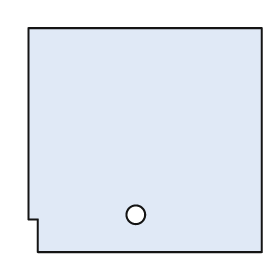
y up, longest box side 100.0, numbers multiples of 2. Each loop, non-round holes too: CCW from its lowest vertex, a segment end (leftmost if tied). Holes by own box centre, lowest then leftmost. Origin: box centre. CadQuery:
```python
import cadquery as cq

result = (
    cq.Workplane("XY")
    .moveTo(-46.0, -48.0)
    .lineTo(50.0, -48.0)
    .lineTo(50.0, 48.0)
    .lineTo(-50.0, 48.0)
    .lineTo(-50.0, -34.0)
    .lineTo(-46.0, -34.0)
    .close()
    .moveTo(-4.0, -32.0)
    .circle(4.0)
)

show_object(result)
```